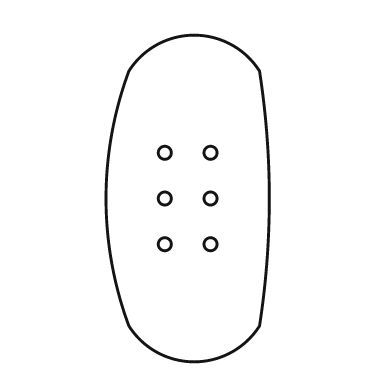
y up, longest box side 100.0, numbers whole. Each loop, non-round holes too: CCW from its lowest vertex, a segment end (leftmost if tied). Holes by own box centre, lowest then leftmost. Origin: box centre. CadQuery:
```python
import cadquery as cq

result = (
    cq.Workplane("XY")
    .moveTo(-18.0, -39.0)
    .threePointArc((2.0, -50.0), (22.0, -39.0))
    .threePointArc((25.0, 0.0), (22.0, 39.0))
    .threePointArc((2.0, 50.0), (-18.0, 39.0))
    .threePointArc((-25.0, 0.0), (-18.0, -39.0))
    .close()
    .moveTo(-7.0, -14.0)
    .circle(2.0)
    .moveTo(7.0, -14.0)
    .circle(2.0)
    .moveTo(-7.0, 0.0)
    .circle(2.0)
    .moveTo(7.0, 0.0)
    .circle(2.0)
    .moveTo(-7.0, 14.0)
    .circle(2.0)
    .moveTo(7.0, 14.0)
    .circle(2.0)
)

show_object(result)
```